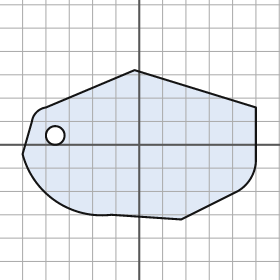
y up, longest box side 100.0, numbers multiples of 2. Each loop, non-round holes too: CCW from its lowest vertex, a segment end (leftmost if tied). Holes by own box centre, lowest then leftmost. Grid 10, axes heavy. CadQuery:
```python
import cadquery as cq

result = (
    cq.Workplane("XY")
    .moveTo(18.0, -32.0)
    .lineTo(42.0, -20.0)
    .threePointArc((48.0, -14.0), (50.0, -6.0))
    .lineTo(50.0, 16.0)
    .lineTo(-2.0, 32.0)
    .lineTo(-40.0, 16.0)
    .threePointArc((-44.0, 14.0), (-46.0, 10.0))
    .lineTo(-50.0, -4.0)
    .threePointArc((-36.0, -24.0), (-12.0, -30.0))
    .close()
    .moveTo(-36.0, 4.0)
    .circle(4.0)
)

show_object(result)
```